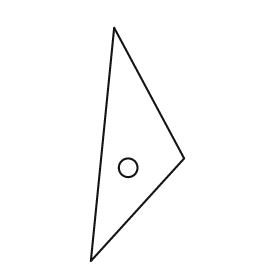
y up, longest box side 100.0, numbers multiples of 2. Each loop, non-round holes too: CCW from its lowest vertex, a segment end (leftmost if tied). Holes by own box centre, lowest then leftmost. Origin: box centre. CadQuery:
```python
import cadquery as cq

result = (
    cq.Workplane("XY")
    .moveTo(-20.0, -50.0)
    .lineTo(20.0, -6.0)
    .lineTo(-10.0, 50.0)
    .close()
    .moveTo(-4.0, -10.0)
    .circle(4.0)
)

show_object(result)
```